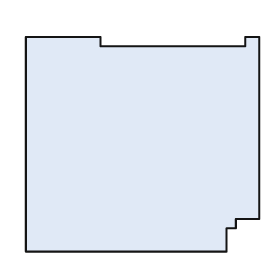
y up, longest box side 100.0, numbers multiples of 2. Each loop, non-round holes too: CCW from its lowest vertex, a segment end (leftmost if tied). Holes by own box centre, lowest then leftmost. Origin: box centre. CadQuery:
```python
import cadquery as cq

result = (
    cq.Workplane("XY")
    .moveTo(-50.0, -46.0)
    .lineTo(36.0, -46.0)
    .lineTo(36.0, -36.0)
    .lineTo(40.0, -36.0)
    .lineTo(40.0, -32.0)
    .lineTo(50.0, -32.0)
    .lineTo(50.0, 46.0)
    .lineTo(44.0, 46.0)
    .lineTo(44.0, 42.0)
    .lineTo(-18.0, 42.0)
    .lineTo(-18.0, 46.0)
    .lineTo(-50.0, 46.0)
    .close()
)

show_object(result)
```